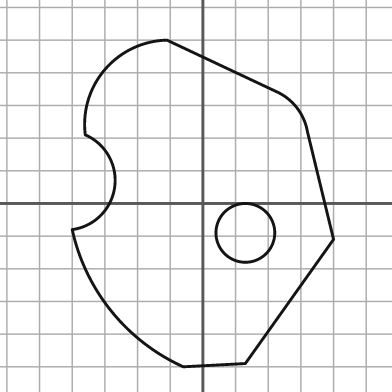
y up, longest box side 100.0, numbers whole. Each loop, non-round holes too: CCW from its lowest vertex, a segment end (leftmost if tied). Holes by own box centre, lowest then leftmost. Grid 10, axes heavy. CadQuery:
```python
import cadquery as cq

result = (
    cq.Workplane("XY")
    .moveTo(-6.0, -50.0)
    .lineTo(13.0, -49.0)
    .lineTo(40.0, -11.0)
    .lineTo(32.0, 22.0)
    .threePointArc((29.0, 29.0), (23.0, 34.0))
    .lineTo(-11.0, 50.0)
    .threePointArc((-30.0, 41.0), (-36.0, 21.0))
    .threePointArc((-27.0, 5.0), (-40.0, -8.0))
    .threePointArc((-28.0, -33.0), (-6.0, -50.0))
    .close()
    .moveTo(13.0, -9.0)
    .circle(9.0)
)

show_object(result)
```